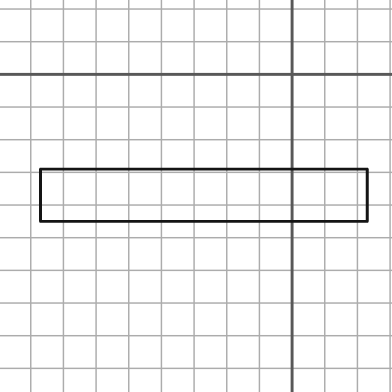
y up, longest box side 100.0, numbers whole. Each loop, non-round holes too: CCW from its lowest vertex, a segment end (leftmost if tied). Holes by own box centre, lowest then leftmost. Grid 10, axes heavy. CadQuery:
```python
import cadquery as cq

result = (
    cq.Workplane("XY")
    .moveTo(-77.0, -45.0)
    .lineTo(23.0, -45.0)
    .lineTo(23.0, -29.0)
    .lineTo(-77.0, -29.0)
    .close()
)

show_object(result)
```